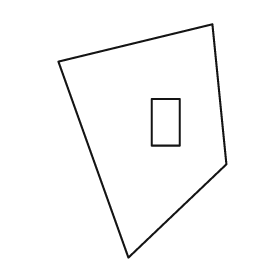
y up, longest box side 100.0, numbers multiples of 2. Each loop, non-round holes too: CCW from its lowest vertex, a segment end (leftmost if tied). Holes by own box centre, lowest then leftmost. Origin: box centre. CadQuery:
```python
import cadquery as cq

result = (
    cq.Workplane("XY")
    .moveTo(-6.0, -50.0)
    .lineTo(36.0, -10.0)
    .lineTo(30.0, 50.0)
    .lineTo(-36.0, 34.0)
    .close()
    .moveTo(4.0, -2.0)
    .lineTo(16.0, -2.0)
    .lineTo(16.0, 18.0)
    .lineTo(4.0, 18.0)
    .close()
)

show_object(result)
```